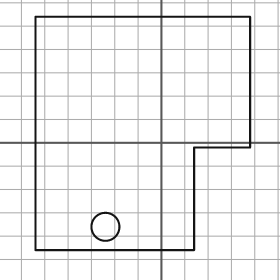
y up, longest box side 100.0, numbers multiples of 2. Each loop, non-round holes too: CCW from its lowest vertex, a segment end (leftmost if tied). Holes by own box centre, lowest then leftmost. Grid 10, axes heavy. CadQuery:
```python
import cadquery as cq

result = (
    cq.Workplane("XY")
    .moveTo(-54.0, -46.0)
    .lineTo(14.0, -46.0)
    .lineTo(14.0, -2.0)
    .lineTo(38.0, -2.0)
    .lineTo(38.0, 54.0)
    .lineTo(-54.0, 54.0)
    .close()
    .moveTo(-24.0, -36.0)
    .circle(6.0)
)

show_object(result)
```